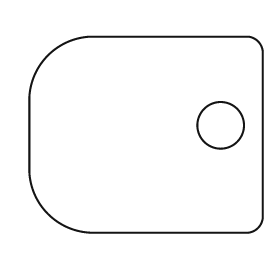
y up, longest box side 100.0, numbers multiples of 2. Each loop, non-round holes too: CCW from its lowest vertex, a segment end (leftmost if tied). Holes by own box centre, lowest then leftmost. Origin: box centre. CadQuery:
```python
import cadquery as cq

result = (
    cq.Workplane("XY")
    .moveTo(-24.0, -42.0)
    .lineTo(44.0, -42.0)
    .threePointArc((48.0, -40.0), (50.0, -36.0))
    .lineTo(50.0, 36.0)
    .threePointArc((48.0, 40.0), (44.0, 42.0))
    .lineTo(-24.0, 42.0)
    .threePointArc((-42.0, 34.0), (-50.0, 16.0))
    .lineTo(-50.0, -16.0)
    .threePointArc((-42.0, -34.0), (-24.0, -42.0))
    .close()
    .moveTo(32.0, 4.0)
    .circle(10.0)
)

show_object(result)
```